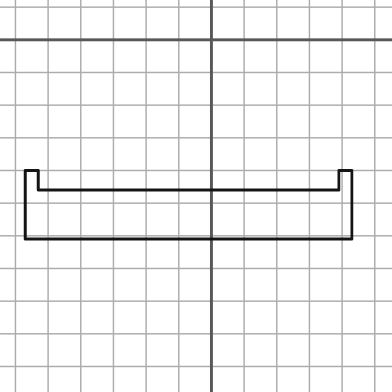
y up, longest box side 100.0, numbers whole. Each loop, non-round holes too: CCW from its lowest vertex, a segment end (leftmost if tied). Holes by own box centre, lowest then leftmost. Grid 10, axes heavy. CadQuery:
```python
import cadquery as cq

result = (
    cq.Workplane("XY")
    .moveTo(-57.0, -61.0)
    .lineTo(43.0, -61.0)
    .lineTo(43.0, -40.0)
    .lineTo(39.0, -40.0)
    .lineTo(39.0, -46.0)
    .lineTo(-53.0, -46.0)
    .lineTo(-53.0, -40.0)
    .lineTo(-57.0, -40.0)
    .close()
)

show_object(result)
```